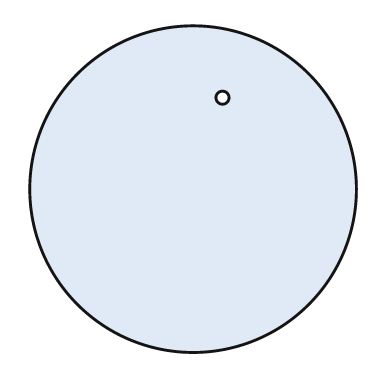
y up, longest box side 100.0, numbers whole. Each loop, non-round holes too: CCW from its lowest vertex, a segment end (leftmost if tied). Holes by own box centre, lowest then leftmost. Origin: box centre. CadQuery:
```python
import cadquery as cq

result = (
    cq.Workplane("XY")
    .moveTo(0.0, 0.0)
    .circle(50.0)
    .moveTo(9.0, 28.0)
    .circle(2.0)
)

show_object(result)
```